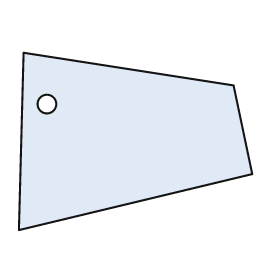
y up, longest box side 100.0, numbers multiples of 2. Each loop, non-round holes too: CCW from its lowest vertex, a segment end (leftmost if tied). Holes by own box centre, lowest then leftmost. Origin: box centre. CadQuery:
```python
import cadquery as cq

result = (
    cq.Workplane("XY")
    .moveTo(-50.0, -38.0)
    .lineTo(50.0, -14.0)
    .lineTo(42.0, 24.0)
    .lineTo(-48.0, 38.0)
    .close()
    .moveTo(-38.0, 16.0)
    .circle(4.0)
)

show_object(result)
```